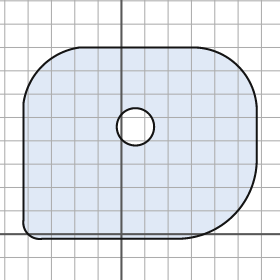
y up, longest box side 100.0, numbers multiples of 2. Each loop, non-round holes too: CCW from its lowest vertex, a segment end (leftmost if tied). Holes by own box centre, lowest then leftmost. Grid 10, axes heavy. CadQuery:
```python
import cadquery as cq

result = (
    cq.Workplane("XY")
    .moveTo(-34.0, -2.0)
    .lineTo(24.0, -2.0)
    .threePointArc((48.0, 8.0), (58.0, 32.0))
    .lineTo(58.0, 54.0)
    .threePointArc((50.0, 72.0), (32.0, 80.0))
    .lineTo(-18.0, 80.0)
    .threePointArc((-34.0, 72.0), (-42.0, 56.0))
    .lineTo(-42.0, 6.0)
    .threePointArc((-40.0, 0.0), (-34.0, -2.0))
    .close()
    .moveTo(6.0, 46.0)
    .circle(8.0)
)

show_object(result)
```